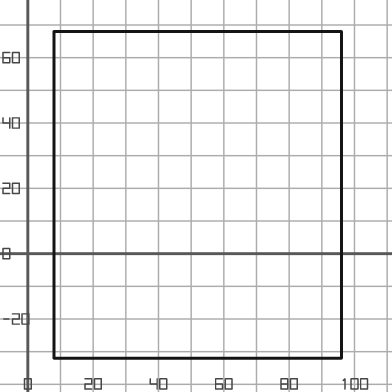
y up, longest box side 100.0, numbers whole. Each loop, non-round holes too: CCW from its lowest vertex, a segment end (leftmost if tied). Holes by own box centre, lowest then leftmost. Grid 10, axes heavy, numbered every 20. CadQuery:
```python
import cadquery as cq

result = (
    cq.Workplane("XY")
    .moveTo(8.0, -32.0)
    .lineTo(96.0, -32.0)
    .lineTo(96.0, 68.0)
    .lineTo(8.0, 68.0)
    .close()
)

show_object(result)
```